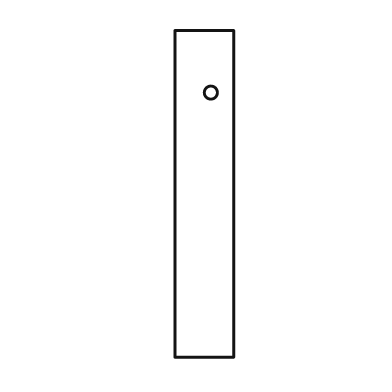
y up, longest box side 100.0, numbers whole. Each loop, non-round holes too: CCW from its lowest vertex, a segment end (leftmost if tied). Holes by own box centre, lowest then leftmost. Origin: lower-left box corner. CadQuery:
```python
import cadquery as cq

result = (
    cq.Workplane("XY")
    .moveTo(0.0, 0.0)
    .lineTo(18.0, 0.0)
    .lineTo(18.0, 100.0)
    .lineTo(0.0, 100.0)
    .close()
    .moveTo(11.0, 81.0)
    .circle(2.0)
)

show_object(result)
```